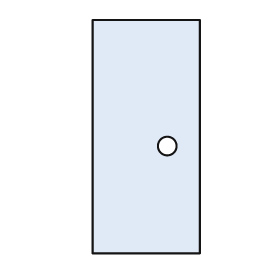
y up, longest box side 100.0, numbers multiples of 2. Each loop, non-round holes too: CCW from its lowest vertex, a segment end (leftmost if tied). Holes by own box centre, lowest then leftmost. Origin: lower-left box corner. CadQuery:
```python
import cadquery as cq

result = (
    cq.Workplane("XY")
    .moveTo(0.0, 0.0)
    .lineTo(46.0, 0.0)
    .lineTo(46.0, 100.0)
    .lineTo(0.0, 100.0)
    .close()
    .moveTo(32.0, 46.0)
    .circle(4.0)
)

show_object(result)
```